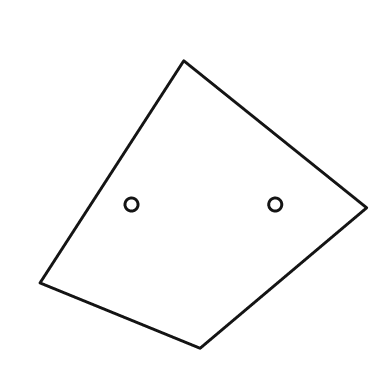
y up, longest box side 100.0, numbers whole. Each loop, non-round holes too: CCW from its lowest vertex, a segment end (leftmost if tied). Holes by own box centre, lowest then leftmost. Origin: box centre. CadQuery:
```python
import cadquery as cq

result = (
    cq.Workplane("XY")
    .moveTo(-1.0, -44.0)
    .lineTo(50.0, -1.0)
    .lineTo(-6.0, 44.0)
    .lineTo(-50.0, -24.0)
    .close()
    .moveTo(-22.0, 0.0)
    .circle(2.0)
    .moveTo(22.0, 0.0)
    .circle(2.0)
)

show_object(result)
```